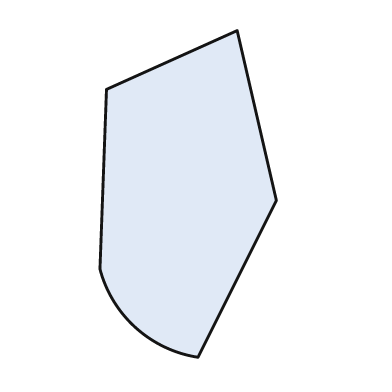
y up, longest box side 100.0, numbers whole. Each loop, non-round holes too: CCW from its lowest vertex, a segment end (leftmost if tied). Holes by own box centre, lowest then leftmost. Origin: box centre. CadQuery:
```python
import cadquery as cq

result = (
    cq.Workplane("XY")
    .moveTo(3.0, -50.0)
    .lineTo(27.0, -2.0)
    .lineTo(15.0, 50.0)
    .lineTo(-25.0, 32.0)
    .lineTo(-27.0, -23.0)
    .threePointArc((-16.0, -41.0), (3.0, -50.0))
    .close()
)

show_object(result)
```